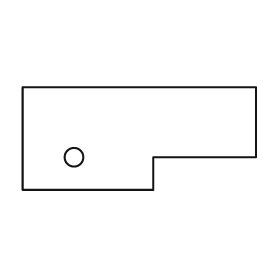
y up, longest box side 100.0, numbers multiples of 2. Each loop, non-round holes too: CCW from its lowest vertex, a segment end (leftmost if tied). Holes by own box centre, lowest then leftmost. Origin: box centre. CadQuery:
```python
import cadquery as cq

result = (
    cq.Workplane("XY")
    .moveTo(-50.0, -22.0)
    .lineTo(6.0, -22.0)
    .lineTo(6.0, -8.0)
    .lineTo(50.0, -8.0)
    .lineTo(50.0, 22.0)
    .lineTo(-50.0, 22.0)
    .close()
    .moveTo(-28.0, -8.0)
    .circle(4.0)
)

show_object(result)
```